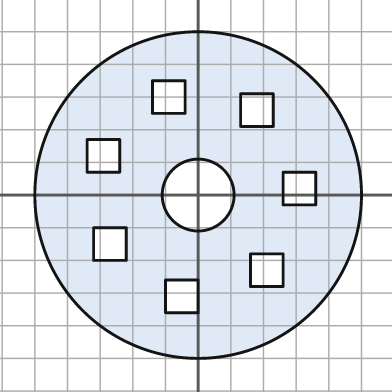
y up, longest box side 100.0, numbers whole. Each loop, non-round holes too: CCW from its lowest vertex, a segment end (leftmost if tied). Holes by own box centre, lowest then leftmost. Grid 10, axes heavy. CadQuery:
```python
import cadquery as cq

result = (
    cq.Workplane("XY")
    .moveTo(0.0, 0.0)
    .circle(50.0)
    .moveTo(-10.0, -36.0)
    .lineTo(0.0, -36.0)
    .lineTo(0.0, -26.0)
    .lineTo(-10.0, -26.0)
    .close()
    .moveTo(16.0, -28.0)
    .lineTo(26.0, -28.0)
    .lineTo(26.0, -18.0)
    .lineTo(16.0, -18.0)
    .close()
    .moveTo(-32.0, -20.0)
    .lineTo(-22.0, -20.0)
    .lineTo(-22.0, -10.0)
    .lineTo(-32.0, -10.0)
    .close()
    .moveTo(0.0, 0.0)
    .circle(11.0)
    .moveTo(26.0, -3.0)
    .lineTo(36.0, -3.0)
    .lineTo(36.0, 7.0)
    .lineTo(26.0, 7.0)
    .close()
    .moveTo(-34.0, 7.0)
    .lineTo(-24.0, 7.0)
    .lineTo(-24.0, 17.0)
    .lineTo(-34.0, 17.0)
    .close()
    .moveTo(13.0, 21.0)
    .lineTo(23.0, 21.0)
    .lineTo(23.0, 31.0)
    .lineTo(13.0, 31.0)
    .close()
    .moveTo(-14.0, 25.0)
    .lineTo(-4.0, 25.0)
    .lineTo(-4.0, 35.0)
    .lineTo(-14.0, 35.0)
    .close()
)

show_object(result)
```